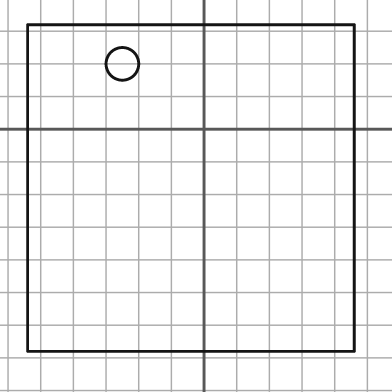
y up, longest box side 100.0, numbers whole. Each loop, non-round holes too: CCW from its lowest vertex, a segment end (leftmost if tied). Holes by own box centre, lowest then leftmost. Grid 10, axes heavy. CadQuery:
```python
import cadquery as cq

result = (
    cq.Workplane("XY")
    .moveTo(-54.0, -68.0)
    .lineTo(46.0, -68.0)
    .lineTo(46.0, 32.0)
    .lineTo(-54.0, 32.0)
    .close()
    .moveTo(-25.0, 20.0)
    .circle(5.0)
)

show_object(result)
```